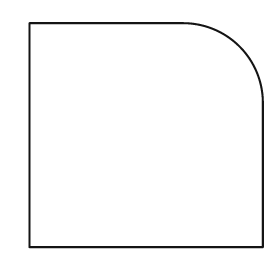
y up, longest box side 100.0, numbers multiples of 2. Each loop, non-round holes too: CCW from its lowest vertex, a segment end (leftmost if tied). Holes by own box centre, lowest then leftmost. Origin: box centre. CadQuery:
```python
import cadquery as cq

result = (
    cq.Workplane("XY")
    .moveTo(-50.0, -48.0)
    .lineTo(50.0, -48.0)
    .lineTo(50.0, 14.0)
    .threePointArc((40.0, 38.0), (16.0, 48.0))
    .lineTo(-50.0, 48.0)
    .close()
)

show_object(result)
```